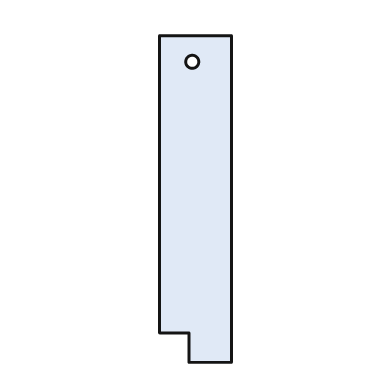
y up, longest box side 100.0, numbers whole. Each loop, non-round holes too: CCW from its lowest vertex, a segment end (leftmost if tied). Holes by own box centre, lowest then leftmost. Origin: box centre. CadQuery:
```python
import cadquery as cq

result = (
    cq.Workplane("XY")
    .moveTo(-2.0, -50.0)
    .lineTo(11.0, -50.0)
    .lineTo(11.0, 50.0)
    .lineTo(-11.0, 50.0)
    .lineTo(-11.0, -41.0)
    .lineTo(-2.0, -41.0)
    .close()
    .moveTo(-1.0, 42.0)
    .circle(2.0)
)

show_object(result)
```